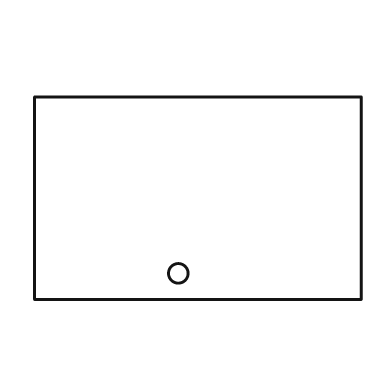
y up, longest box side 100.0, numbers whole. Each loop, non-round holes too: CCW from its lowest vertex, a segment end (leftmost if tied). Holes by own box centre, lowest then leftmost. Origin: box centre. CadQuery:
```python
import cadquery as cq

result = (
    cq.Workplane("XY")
    .moveTo(-50.0, -31.0)
    .lineTo(50.0, -31.0)
    .lineTo(50.0, 31.0)
    .lineTo(-50.0, 31.0)
    .close()
    .moveTo(-6.0, -23.0)
    .circle(3.0)
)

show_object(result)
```